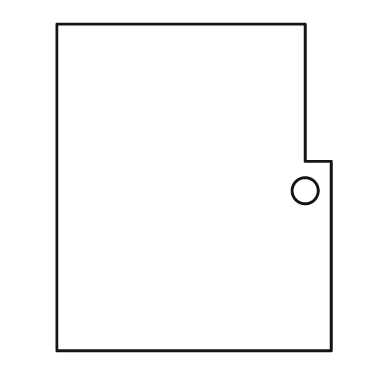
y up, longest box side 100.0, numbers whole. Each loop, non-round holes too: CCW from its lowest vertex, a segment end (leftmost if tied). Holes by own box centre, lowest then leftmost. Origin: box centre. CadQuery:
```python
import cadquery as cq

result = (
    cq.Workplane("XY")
    .moveTo(-42.0, -50.0)
    .lineTo(42.0, -50.0)
    .lineTo(42.0, 8.0)
    .lineTo(34.0, 8.0)
    .lineTo(34.0, 50.0)
    .lineTo(-42.0, 50.0)
    .close()
    .moveTo(34.0, -1.0)
    .circle(4.0)
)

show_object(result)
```